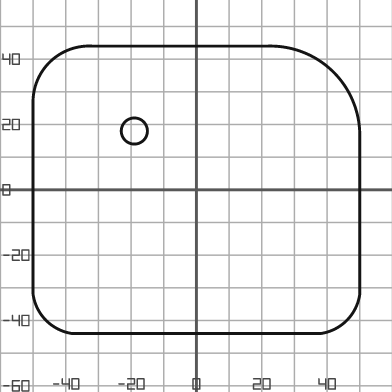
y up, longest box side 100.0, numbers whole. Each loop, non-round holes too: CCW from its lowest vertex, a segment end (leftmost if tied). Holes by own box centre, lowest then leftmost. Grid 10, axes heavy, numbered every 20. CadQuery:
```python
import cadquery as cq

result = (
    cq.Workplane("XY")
    .moveTo(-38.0, -44.0)
    .lineTo(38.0, -44.0)
    .threePointArc((46.0, -40.0), (50.0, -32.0))
    .lineTo(50.0, 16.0)
    .threePointArc((42.0, 36.0), (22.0, 44.0))
    .lineTo(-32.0, 44.0)
    .threePointArc((-45.0, 39.0), (-50.0, 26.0))
    .lineTo(-50.0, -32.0)
    .threePointArc((-46.0, -40.0), (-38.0, -44.0))
    .close()
    .moveTo(-19.0, 18.0)
    .circle(4.0)
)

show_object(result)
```